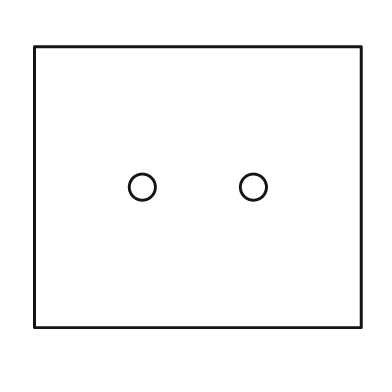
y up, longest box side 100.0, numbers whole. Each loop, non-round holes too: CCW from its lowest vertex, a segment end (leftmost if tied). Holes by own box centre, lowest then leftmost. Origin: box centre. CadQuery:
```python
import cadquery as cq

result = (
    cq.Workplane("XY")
    .moveTo(-50.0, -43.0)
    .lineTo(50.0, -43.0)
    .lineTo(50.0, 43.0)
    .lineTo(-50.0, 43.0)
    .close()
    .moveTo(-17.0, 0.0)
    .circle(4.0)
    .moveTo(17.0, 0.0)
    .circle(4.0)
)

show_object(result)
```